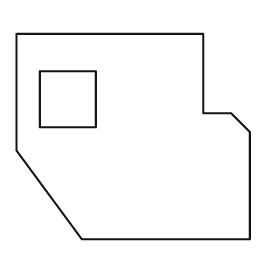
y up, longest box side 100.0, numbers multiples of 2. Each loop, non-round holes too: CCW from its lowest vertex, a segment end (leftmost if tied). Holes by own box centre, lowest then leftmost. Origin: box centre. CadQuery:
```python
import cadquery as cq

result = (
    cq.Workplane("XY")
    .moveTo(-22.0, -44.0)
    .lineTo(50.0, -44.0)
    .lineTo(50.0, 2.0)
    .lineTo(42.0, 10.0)
    .lineTo(30.0, 10.0)
    .lineTo(30.0, 44.0)
    .lineTo(-50.0, 44.0)
    .lineTo(-50.0, -6.0)
    .close()
    .moveTo(-40.0, 4.0)
    .lineTo(-16.0, 4.0)
    .lineTo(-16.0, 28.0)
    .lineTo(-40.0, 28.0)
    .close()
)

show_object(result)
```